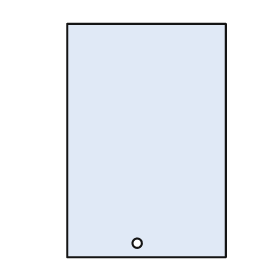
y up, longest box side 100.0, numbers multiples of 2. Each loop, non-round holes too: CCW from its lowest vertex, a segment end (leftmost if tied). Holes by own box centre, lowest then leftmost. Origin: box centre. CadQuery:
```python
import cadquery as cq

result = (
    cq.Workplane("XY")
    .moveTo(-34.0, -50.0)
    .lineTo(34.0, -50.0)
    .lineTo(34.0, 50.0)
    .lineTo(-34.0, 50.0)
    .close()
    .moveTo(-4.0, -44.0)
    .circle(2.0)
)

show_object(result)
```